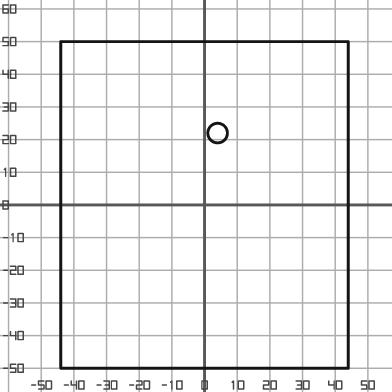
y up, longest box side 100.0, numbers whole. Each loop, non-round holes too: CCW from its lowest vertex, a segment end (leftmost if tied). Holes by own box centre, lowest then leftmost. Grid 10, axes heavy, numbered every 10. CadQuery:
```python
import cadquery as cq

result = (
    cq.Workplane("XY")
    .moveTo(-44.0, -50.0)
    .lineTo(44.0, -50.0)
    .lineTo(44.0, 50.0)
    .lineTo(-44.0, 50.0)
    .close()
    .moveTo(4.0, 22.0)
    .circle(3.0)
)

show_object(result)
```